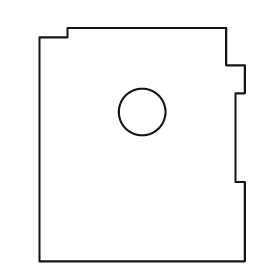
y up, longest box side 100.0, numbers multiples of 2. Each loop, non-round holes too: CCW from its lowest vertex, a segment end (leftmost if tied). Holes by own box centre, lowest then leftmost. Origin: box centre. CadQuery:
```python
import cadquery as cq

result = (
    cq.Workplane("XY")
    .moveTo(-44.0, -50.0)
    .lineTo(44.0, -50.0)
    .lineTo(44.0, -16.0)
    .lineTo(40.0, -16.0)
    .lineTo(40.0, 22.0)
    .lineTo(44.0, 22.0)
    .lineTo(44.0, 34.0)
    .lineTo(36.0, 34.0)
    .lineTo(36.0, 50.0)
    .lineTo(-32.0, 50.0)
    .lineTo(-32.0, 46.0)
    .lineTo(-44.0, 46.0)
    .close()
    .moveTo(0.0, 14.0)
    .circle(10.0)
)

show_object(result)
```